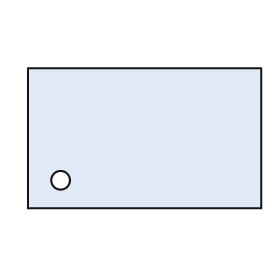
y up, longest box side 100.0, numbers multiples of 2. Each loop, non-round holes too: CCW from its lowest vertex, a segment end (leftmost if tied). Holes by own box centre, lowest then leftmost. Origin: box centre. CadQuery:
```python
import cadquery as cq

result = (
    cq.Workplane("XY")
    .moveTo(-50.0, -30.0)
    .lineTo(50.0, -30.0)
    .lineTo(50.0, 30.0)
    .lineTo(-50.0, 30.0)
    .close()
    .moveTo(-36.0, -18.0)
    .circle(4.0)
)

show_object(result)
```